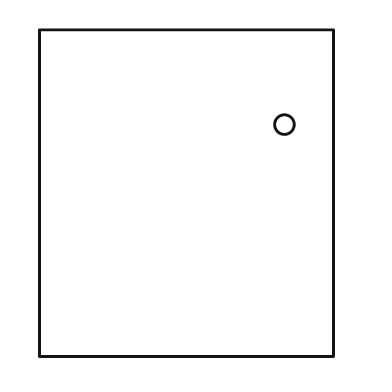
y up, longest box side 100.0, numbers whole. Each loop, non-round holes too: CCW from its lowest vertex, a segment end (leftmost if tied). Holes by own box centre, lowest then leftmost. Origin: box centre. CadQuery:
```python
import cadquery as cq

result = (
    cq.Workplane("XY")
    .moveTo(-45.0, -50.0)
    .lineTo(45.0, -50.0)
    .lineTo(45.0, 50.0)
    .lineTo(-45.0, 50.0)
    .close()
    .moveTo(30.0, 21.0)
    .circle(3.0)
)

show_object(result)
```